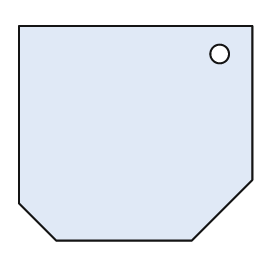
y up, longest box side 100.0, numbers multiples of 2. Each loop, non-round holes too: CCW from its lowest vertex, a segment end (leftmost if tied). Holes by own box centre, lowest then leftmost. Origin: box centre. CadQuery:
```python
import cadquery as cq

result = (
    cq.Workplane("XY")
    .moveTo(-34.0, -46.0)
    .lineTo(24.0, -46.0)
    .lineTo(50.0, -20.0)
    .lineTo(50.0, 46.0)
    .lineTo(-50.0, 46.0)
    .lineTo(-50.0, -30.0)
    .close()
    .moveTo(36.0, 34.0)
    .circle(4.0)
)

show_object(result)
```